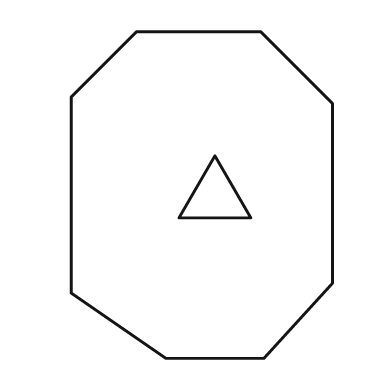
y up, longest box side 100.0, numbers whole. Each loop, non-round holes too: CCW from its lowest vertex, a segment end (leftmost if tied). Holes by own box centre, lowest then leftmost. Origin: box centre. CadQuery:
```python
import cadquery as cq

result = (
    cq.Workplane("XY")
    .moveTo(-11.0, -50.0)
    .lineTo(19.0, -50.0)
    .lineTo(40.0, -27.0)
    .lineTo(40.0, 28.0)
    .lineTo(18.0, 50.0)
    .lineTo(-20.0, 50.0)
    .lineTo(-40.0, 30.0)
    .lineTo(-40.0, -30.0)
    .close()
    .moveTo(-7.0, -7.0)
    .lineTo(15.0, -7.0)
    .lineTo(4.0, 12.0)
    .close()
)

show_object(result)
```